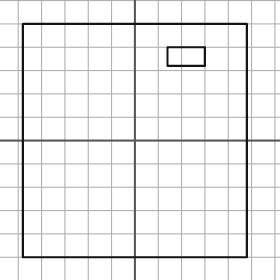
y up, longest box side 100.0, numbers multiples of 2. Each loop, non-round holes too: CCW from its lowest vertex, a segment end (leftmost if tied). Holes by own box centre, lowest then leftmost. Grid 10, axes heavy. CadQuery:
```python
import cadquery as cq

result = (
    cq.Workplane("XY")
    .moveTo(-48.0, -50.0)
    .lineTo(48.0, -50.0)
    .lineTo(48.0, 50.0)
    .lineTo(-48.0, 50.0)
    .close()
    .moveTo(14.0, 32.0)
    .lineTo(30.0, 32.0)
    .lineTo(30.0, 40.0)
    .lineTo(14.0, 40.0)
    .close()
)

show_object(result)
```